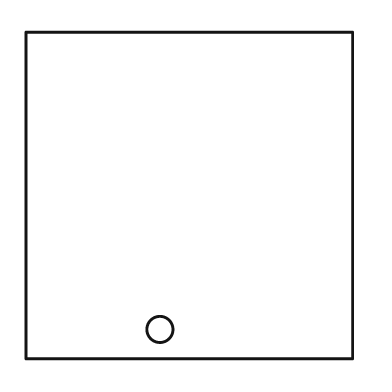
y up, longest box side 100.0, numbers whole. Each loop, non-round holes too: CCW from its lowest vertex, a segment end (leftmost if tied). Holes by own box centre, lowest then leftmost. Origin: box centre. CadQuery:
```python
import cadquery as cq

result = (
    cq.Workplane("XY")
    .moveTo(-50.0, -50.0)
    .lineTo(50.0, -50.0)
    .lineTo(50.0, 50.0)
    .lineTo(-50.0, 50.0)
    .close()
    .moveTo(-9.0, -41.0)
    .circle(4.0)
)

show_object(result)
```